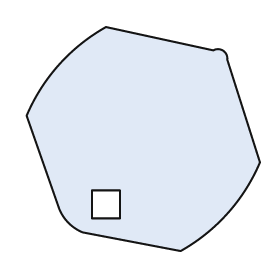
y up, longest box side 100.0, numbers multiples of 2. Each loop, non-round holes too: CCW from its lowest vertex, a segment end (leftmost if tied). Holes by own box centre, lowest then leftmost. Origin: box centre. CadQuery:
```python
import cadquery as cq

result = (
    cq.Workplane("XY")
    .moveTo(16.0, -48.0)
    .threePointArc((36.0, -32.0), (50.0, -10.0))
    .lineTo(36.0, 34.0)
    .threePointArc((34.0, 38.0), (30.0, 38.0))
    .lineTo(-16.0, 48.0)
    .threePointArc((-36.0, 32.0), (-50.0, 10.0))
    .lineTo(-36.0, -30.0)
    .threePointArc((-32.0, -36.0), (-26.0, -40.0))
    .close()
    .moveTo(-22.0, -34.0)
    .lineTo(-10.0, -34.0)
    .lineTo(-10.0, -22.0)
    .lineTo(-22.0, -22.0)
    .close()
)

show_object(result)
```